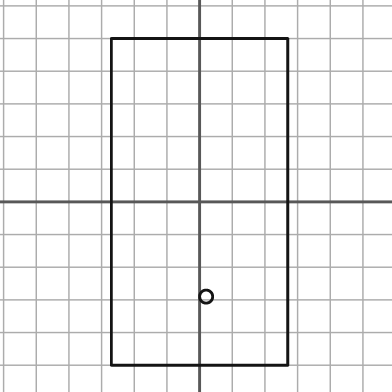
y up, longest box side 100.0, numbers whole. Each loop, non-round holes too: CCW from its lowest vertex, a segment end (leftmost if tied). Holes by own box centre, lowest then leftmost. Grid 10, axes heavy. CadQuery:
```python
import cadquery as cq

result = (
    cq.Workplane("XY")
    .moveTo(-27.0, -50.0)
    .lineTo(27.0, -50.0)
    .lineTo(27.0, 50.0)
    .lineTo(-27.0, 50.0)
    .close()
    .moveTo(2.0, -29.0)
    .circle(2.0)
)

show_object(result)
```